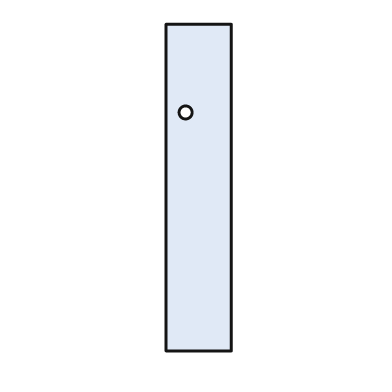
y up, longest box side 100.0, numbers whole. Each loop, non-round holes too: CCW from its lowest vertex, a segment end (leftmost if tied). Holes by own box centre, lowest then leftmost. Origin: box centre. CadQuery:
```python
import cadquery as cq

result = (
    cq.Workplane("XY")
    .moveTo(-10.0, -50.0)
    .lineTo(10.0, -50.0)
    .lineTo(10.0, 50.0)
    .lineTo(-10.0, 50.0)
    .close()
    .moveTo(-4.0, 23.0)
    .circle(2.0)
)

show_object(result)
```